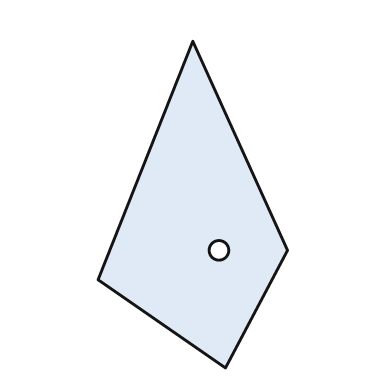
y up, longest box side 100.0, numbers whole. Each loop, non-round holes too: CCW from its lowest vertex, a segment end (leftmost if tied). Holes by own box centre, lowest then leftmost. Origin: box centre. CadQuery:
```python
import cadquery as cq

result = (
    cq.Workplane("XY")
    .moveTo(10.0, -50.0)
    .lineTo(29.0, -14.0)
    .lineTo(0.0, 50.0)
    .lineTo(-29.0, -23.0)
    .close()
    .moveTo(8.0, -14.0)
    .circle(3.0)
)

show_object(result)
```